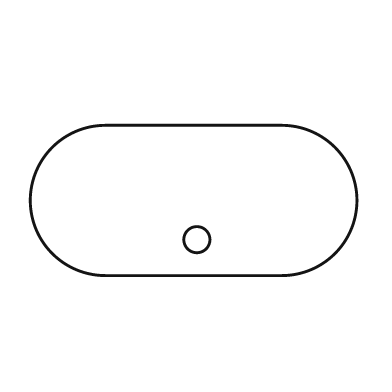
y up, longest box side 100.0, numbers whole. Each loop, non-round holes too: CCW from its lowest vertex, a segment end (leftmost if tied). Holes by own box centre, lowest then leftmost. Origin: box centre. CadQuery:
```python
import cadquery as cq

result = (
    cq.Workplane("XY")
    .moveTo(-27.0, -23.0)
    .lineTo(27.0, -23.0)
    .threePointArc((50.0, 0.0), (27.0, 23.0))
    .lineTo(-27.0, 23.0)
    .threePointArc((-50.0, 0.0), (-27.0, -23.0))
    .close()
    .moveTo(1.0, -12.0)
    .circle(4.0)
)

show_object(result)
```